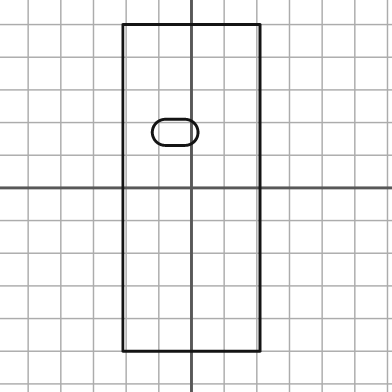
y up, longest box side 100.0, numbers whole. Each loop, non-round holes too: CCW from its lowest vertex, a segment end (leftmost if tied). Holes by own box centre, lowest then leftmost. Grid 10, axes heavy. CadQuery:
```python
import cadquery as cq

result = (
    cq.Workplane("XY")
    .moveTo(-21.0, -50.0)
    .lineTo(21.0, -50.0)
    .lineTo(21.0, 50.0)
    .lineTo(-21.0, 50.0)
    .close()
    .moveTo(-8.0, 13.0)
    .lineTo(-2.0, 13.0)
    .threePointArc((2.0, 17.0), (-2.0, 21.0))
    .lineTo(-8.0, 21.0)
    .threePointArc((-12.0, 17.0), (-8.0, 13.0))
    .close()
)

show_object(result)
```